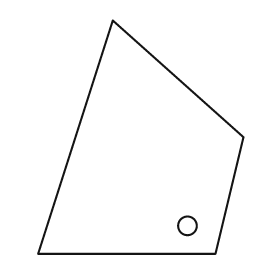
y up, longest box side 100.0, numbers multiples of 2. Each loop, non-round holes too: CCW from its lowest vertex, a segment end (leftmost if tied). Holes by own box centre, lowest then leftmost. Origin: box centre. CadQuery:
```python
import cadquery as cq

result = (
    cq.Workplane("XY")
    .moveTo(-44.0, -50.0)
    .lineTo(32.0, -50.0)
    .lineTo(44.0, 0.0)
    .lineTo(-12.0, 50.0)
    .close()
    .moveTo(20.0, -38.0)
    .circle(4.0)
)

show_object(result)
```